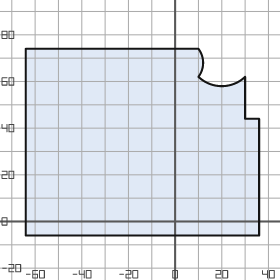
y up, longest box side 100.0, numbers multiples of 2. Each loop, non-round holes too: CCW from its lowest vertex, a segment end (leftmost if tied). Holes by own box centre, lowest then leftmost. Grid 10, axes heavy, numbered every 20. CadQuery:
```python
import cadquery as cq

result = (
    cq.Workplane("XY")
    .moveTo(-64.0, -6.0)
    .lineTo(36.0, -6.0)
    .lineTo(36.0, 44.0)
    .lineTo(30.0, 44.0)
    .lineTo(30.0, 62.0)
    .threePointArc((20.0, 58.0), (10.0, 62.0))
    .threePointArc((12.0, 68.0), (10.0, 74.0))
    .lineTo(-64.0, 74.0)
    .close()
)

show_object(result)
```